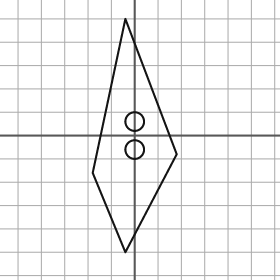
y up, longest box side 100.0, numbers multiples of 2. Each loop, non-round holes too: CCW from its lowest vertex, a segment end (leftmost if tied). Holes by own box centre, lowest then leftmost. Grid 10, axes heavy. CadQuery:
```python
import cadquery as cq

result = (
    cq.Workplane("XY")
    .moveTo(-4.0, -50.0)
    .lineTo(18.0, -8.0)
    .lineTo(-4.0, 50.0)
    .lineTo(-18.0, -16.0)
    .close()
    .moveTo(0.0, -6.0)
    .circle(4.0)
    .moveTo(0.0, 6.0)
    .circle(4.0)
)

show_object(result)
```